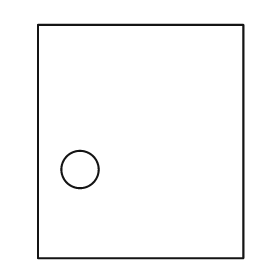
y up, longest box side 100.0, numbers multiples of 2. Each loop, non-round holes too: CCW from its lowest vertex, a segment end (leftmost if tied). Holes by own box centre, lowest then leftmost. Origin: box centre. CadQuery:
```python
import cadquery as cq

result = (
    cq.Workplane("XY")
    .moveTo(-44.0, -50.0)
    .lineTo(44.0, -50.0)
    .lineTo(44.0, 50.0)
    .lineTo(-44.0, 50.0)
    .close()
    .moveTo(-26.0, -12.0)
    .circle(8.0)
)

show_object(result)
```